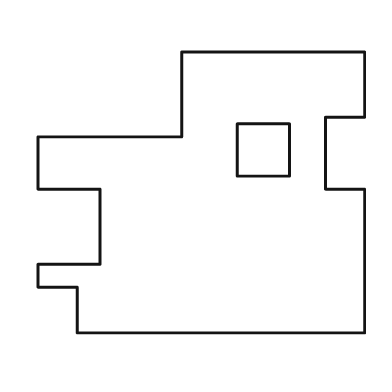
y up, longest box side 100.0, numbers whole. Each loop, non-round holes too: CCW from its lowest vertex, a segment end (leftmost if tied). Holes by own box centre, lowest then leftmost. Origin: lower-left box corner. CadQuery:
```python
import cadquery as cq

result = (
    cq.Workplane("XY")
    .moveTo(12.0, 0.0)
    .lineTo(100.0, 0.0)
    .lineTo(100.0, 44.0)
    .lineTo(88.0, 44.0)
    .lineTo(88.0, 66.0)
    .lineTo(100.0, 66.0)
    .lineTo(100.0, 86.0)
    .lineTo(44.0, 86.0)
    .lineTo(44.0, 60.0)
    .lineTo(0.0, 60.0)
    .lineTo(0.0, 44.0)
    .lineTo(19.0, 44.0)
    .lineTo(19.0, 21.0)
    .lineTo(0.0, 21.0)
    .lineTo(0.0, 14.0)
    .lineTo(12.0, 14.0)
    .close()
    .moveTo(61.0, 48.0)
    .lineTo(77.0, 48.0)
    .lineTo(77.0, 64.0)
    .lineTo(61.0, 64.0)
    .close()
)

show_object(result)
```